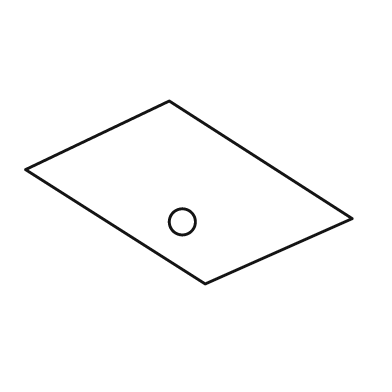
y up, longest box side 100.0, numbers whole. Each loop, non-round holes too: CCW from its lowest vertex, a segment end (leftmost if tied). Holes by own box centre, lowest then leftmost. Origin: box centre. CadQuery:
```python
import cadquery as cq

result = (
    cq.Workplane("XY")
    .moveTo(5.0, -28.0)
    .lineTo(50.0, -8.0)
    .lineTo(-6.0, 28.0)
    .lineTo(-50.0, 7.0)
    .close()
    .moveTo(-2.0, -9.0)
    .circle(4.0)
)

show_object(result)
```